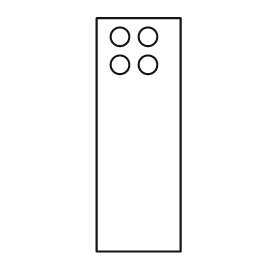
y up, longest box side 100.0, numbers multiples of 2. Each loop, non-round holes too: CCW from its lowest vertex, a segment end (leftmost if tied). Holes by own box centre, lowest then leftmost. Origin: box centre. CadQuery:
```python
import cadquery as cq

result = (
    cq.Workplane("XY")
    .moveTo(-18.0, -50.0)
    .lineTo(18.0, -50.0)
    .lineTo(18.0, 50.0)
    .lineTo(-18.0, 50.0)
    .close()
    .moveTo(-8.0, 30.0)
    .circle(4.0)
    .moveTo(4.0, 30.0)
    .circle(4.0)
    .moveTo(-8.0, 42.0)
    .circle(4.0)
    .moveTo(4.0, 42.0)
    .circle(4.0)
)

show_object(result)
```